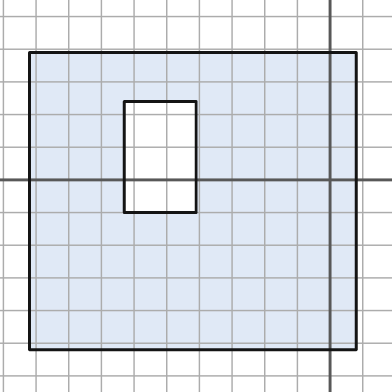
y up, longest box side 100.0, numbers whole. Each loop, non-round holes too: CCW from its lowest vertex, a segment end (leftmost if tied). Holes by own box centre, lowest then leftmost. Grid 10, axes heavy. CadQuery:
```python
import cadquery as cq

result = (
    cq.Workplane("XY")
    .moveTo(-92.0, -52.0)
    .lineTo(8.0, -52.0)
    .lineTo(8.0, 39.0)
    .lineTo(-92.0, 39.0)
    .close()
    .moveTo(-63.0, -10.0)
    .lineTo(-41.0, -10.0)
    .lineTo(-41.0, 24.0)
    .lineTo(-63.0, 24.0)
    .close()
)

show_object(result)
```